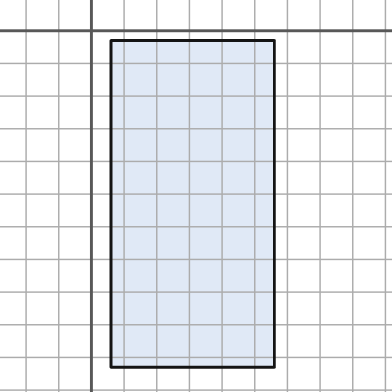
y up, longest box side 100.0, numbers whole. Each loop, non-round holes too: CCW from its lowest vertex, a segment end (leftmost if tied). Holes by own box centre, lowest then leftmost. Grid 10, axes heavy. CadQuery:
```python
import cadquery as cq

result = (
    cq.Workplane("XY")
    .moveTo(6.0, -103.0)
    .lineTo(56.0, -103.0)
    .lineTo(56.0, -3.0)
    .lineTo(6.0, -3.0)
    .close()
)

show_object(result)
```